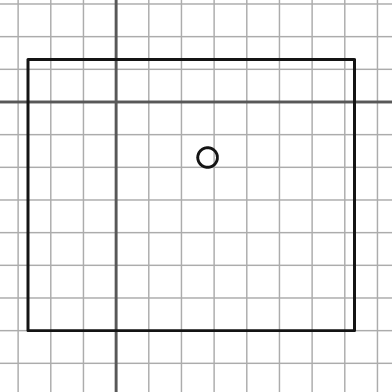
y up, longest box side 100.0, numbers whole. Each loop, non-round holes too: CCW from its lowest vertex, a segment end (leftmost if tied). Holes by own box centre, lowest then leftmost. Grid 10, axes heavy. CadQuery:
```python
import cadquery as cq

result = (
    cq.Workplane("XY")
    .moveTo(-27.0, -70.0)
    .lineTo(73.0, -70.0)
    .lineTo(73.0, 13.0)
    .lineTo(-27.0, 13.0)
    .close()
    .moveTo(28.0, -17.0)
    .circle(3.0)
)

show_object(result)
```